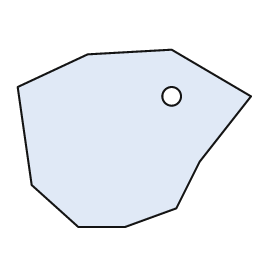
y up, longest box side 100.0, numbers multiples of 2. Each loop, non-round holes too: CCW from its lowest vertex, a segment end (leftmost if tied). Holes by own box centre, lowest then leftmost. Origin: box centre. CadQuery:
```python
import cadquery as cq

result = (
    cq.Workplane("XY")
    .moveTo(-24.0, -38.0)
    .lineTo(-4.0, -38.0)
    .lineTo(18.0, -30.0)
    .lineTo(28.0, -10.0)
    .lineTo(50.0, 18.0)
    .lineTo(16.0, 38.0)
    .lineTo(-20.0, 36.0)
    .lineTo(-50.0, 22.0)
    .lineTo(-44.0, -20.0)
    .close()
    .moveTo(16.0, 18.0)
    .circle(4.0)
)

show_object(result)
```